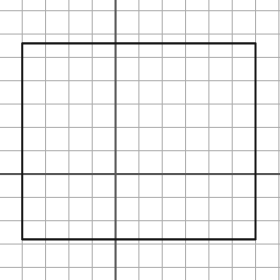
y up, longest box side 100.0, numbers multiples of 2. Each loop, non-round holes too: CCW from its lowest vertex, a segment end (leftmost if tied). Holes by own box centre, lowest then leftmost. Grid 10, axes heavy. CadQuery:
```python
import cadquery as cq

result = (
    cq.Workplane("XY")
    .moveTo(-40.0, -28.0)
    .lineTo(60.0, -28.0)
    .lineTo(60.0, 56.0)
    .lineTo(-40.0, 56.0)
    .close()
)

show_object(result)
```